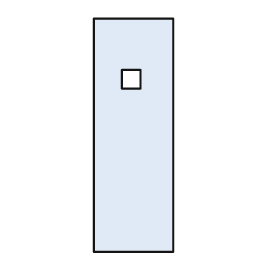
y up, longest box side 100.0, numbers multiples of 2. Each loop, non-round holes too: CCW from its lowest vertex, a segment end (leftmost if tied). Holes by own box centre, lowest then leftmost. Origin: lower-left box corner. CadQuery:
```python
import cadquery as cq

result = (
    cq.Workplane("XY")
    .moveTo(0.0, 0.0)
    .lineTo(34.0, 0.0)
    .lineTo(34.0, 100.0)
    .lineTo(0.0, 100.0)
    .close()
    .moveTo(12.0, 70.0)
    .lineTo(20.0, 70.0)
    .lineTo(20.0, 78.0)
    .lineTo(12.0, 78.0)
    .close()
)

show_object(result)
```